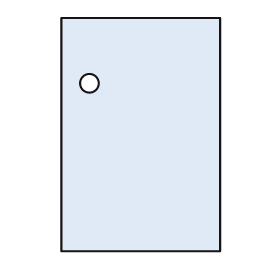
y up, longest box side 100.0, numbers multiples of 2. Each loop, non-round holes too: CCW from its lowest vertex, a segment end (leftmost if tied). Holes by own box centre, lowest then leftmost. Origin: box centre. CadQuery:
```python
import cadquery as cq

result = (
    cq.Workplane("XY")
    .moveTo(-34.0, -50.0)
    .lineTo(34.0, -50.0)
    .lineTo(34.0, 50.0)
    .lineTo(-34.0, 50.0)
    .close()
    .moveTo(-22.0, 22.0)
    .circle(4.0)
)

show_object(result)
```